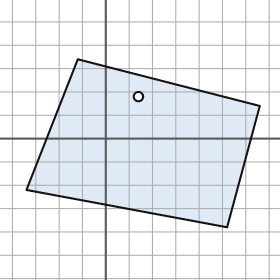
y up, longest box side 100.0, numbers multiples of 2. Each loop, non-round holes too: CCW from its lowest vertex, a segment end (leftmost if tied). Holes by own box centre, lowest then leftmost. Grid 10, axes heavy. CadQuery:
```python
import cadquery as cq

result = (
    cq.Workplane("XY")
    .moveTo(52.0, -38.0)
    .lineTo(66.0, 14.0)
    .lineTo(-12.0, 34.0)
    .lineTo(-34.0, -22.0)
    .close()
    .moveTo(14.0, 18.0)
    .circle(2.0)
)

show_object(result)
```